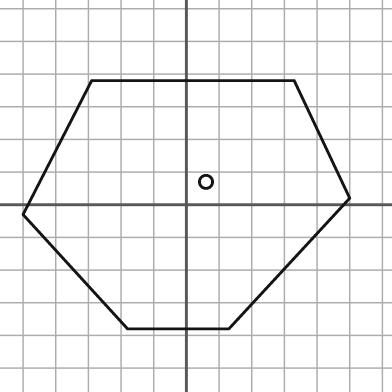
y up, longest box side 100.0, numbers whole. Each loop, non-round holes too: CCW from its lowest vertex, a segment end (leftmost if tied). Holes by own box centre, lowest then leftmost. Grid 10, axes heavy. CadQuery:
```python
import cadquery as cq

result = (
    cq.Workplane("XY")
    .moveTo(-18.0, -38.0)
    .lineTo(13.0, -38.0)
    .lineTo(50.0, 2.0)
    .lineTo(33.0, 38.0)
    .lineTo(-29.0, 38.0)
    .lineTo(-50.0, -3.0)
    .close()
    .moveTo(6.0, 7.0)
    .circle(2.0)
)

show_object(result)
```